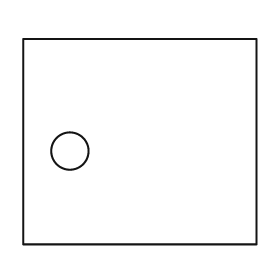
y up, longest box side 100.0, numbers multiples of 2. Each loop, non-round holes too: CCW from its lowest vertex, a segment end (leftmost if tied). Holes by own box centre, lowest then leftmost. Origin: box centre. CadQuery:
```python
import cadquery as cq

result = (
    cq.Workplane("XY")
    .moveTo(-50.0, -44.0)
    .lineTo(50.0, -44.0)
    .lineTo(50.0, 44.0)
    .lineTo(-50.0, 44.0)
    .close()
    .moveTo(-30.0, -4.0)
    .circle(8.0)
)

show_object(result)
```